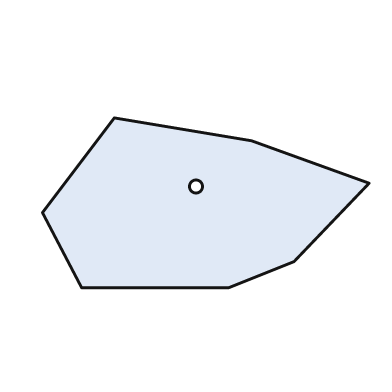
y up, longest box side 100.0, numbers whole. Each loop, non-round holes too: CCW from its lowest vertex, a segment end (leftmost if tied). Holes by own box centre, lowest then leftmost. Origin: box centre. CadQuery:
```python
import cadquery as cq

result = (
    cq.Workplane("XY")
    .moveTo(-38.0, -26.0)
    .lineTo(7.0, -26.0)
    .lineTo(27.0, -18.0)
    .lineTo(50.0, 6.0)
    .lineTo(14.0, 19.0)
    .lineTo(-28.0, 26.0)
    .lineTo(-50.0, -3.0)
    .close()
    .moveTo(-3.0, 5.0)
    .circle(2.0)
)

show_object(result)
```